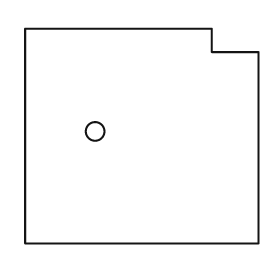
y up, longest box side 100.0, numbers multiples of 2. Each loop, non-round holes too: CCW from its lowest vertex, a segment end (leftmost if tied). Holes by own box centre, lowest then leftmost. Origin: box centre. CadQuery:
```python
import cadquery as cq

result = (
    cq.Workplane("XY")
    .moveTo(-50.0, -46.0)
    .lineTo(50.0, -46.0)
    .lineTo(50.0, 36.0)
    .lineTo(30.0, 36.0)
    .lineTo(30.0, 46.0)
    .lineTo(-50.0, 46.0)
    .close()
    .moveTo(-20.0, 2.0)
    .circle(4.0)
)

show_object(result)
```